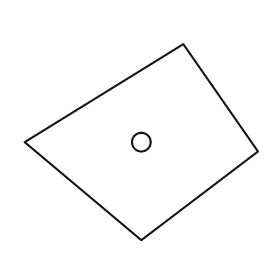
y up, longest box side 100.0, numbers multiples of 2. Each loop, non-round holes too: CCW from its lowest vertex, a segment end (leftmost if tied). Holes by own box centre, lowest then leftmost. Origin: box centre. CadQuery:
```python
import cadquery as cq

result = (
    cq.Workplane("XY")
    .moveTo(0.0, -42.0)
    .lineTo(50.0, -4.0)
    .lineTo(18.0, 42.0)
    .lineTo(-50.0, 0.0)
    .close()
    .moveTo(0.0, 0.0)
    .circle(4.0)
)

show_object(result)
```